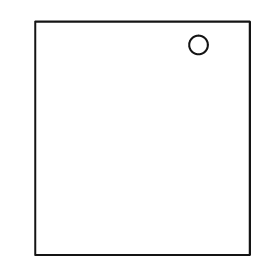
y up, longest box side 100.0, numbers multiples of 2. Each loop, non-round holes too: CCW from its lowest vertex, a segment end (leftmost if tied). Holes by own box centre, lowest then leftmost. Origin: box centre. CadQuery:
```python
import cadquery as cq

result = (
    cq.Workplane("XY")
    .moveTo(-46.0, -50.0)
    .lineTo(46.0, -50.0)
    .lineTo(46.0, 50.0)
    .lineTo(-46.0, 50.0)
    .close()
    .moveTo(24.0, 40.0)
    .circle(4.0)
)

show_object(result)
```